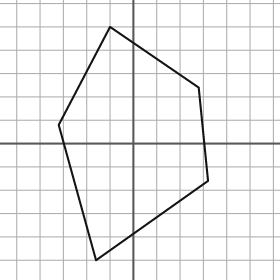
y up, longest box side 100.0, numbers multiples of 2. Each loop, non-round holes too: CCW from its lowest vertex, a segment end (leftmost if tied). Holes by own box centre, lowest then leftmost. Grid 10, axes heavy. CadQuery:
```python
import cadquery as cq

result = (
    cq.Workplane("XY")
    .moveTo(-16.0, -50.0)
    .lineTo(32.0, -16.0)
    .lineTo(28.0, 24.0)
    .lineTo(-10.0, 50.0)
    .lineTo(-32.0, 8.0)
    .close()
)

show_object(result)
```